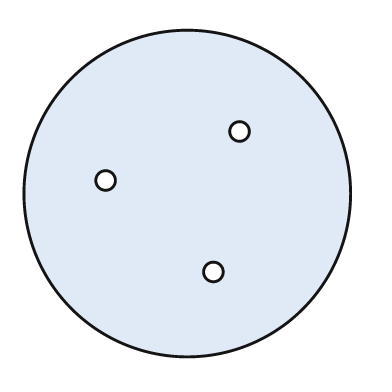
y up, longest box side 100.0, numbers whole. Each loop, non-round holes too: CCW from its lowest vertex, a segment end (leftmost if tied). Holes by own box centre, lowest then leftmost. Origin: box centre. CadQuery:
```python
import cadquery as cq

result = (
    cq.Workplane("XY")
    .moveTo(0.0, 0.0)
    .circle(50.0)
    .moveTo(8.0, -24.0)
    .circle(3.0)
    .moveTo(-25.0, 4.0)
    .circle(3.0)
    .moveTo(16.0, 19.0)
    .circle(3.0)
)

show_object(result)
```